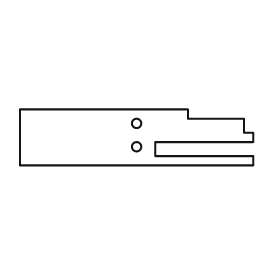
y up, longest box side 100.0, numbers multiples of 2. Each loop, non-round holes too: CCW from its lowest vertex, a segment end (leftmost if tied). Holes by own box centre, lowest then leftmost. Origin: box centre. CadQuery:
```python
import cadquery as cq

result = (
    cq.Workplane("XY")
    .moveTo(-50.0, -12.0)
    .lineTo(50.0, -12.0)
    .lineTo(50.0, -8.0)
    .lineTo(8.0, -8.0)
    .lineTo(8.0, -2.0)
    .lineTo(50.0, -2.0)
    .lineTo(50.0, 2.0)
    .lineTo(46.0, 2.0)
    .lineTo(46.0, 8.0)
    .lineTo(22.0, 8.0)
    .lineTo(22.0, 12.0)
    .lineTo(-50.0, 12.0)
    .close()
    .moveTo(0.0, -4.0)
    .circle(2.0)
    .moveTo(0.0, 6.0)
    .circle(2.0)
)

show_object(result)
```